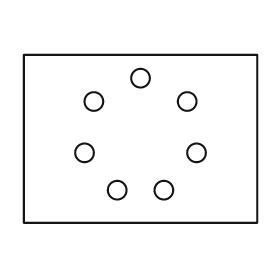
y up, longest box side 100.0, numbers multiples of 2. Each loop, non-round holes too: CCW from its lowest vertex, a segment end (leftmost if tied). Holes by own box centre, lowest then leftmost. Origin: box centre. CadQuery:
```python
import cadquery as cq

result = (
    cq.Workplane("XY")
    .moveTo(-50.0, -36.0)
    .lineTo(50.0, -36.0)
    .lineTo(50.0, 36.0)
    .lineTo(-50.0, 36.0)
    .close()
    .moveTo(-10.0, -22.0)
    .circle(4.0)
    .moveTo(10.0, -22.0)
    .circle(4.0)
    .moveTo(-24.0, -6.0)
    .circle(4.0)
    .moveTo(24.0, -6.0)
    .circle(4.0)
    .moveTo(-20.0, 16.0)
    .circle(4.0)
    .moveTo(20.0, 16.0)
    .circle(4.0)
    .moveTo(0.0, 26.0)
    .circle(4.0)
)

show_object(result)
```